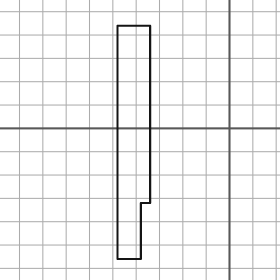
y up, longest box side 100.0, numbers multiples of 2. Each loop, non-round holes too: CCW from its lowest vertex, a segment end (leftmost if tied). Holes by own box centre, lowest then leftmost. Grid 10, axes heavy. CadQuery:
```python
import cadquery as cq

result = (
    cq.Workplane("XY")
    .moveTo(-48.0, -56.0)
    .lineTo(-38.0, -56.0)
    .lineTo(-38.0, -32.0)
    .lineTo(-34.0, -32.0)
    .lineTo(-34.0, 44.0)
    .lineTo(-48.0, 44.0)
    .close()
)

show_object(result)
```